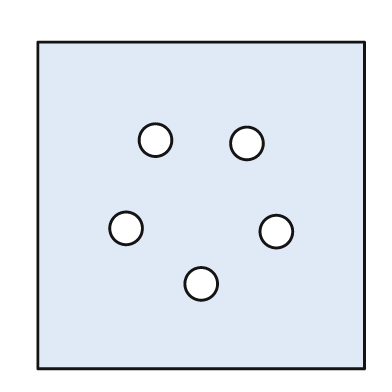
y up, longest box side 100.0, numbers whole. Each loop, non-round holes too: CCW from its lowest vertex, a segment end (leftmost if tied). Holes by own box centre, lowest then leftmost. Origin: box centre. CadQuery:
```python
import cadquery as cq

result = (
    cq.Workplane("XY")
    .moveTo(-50.0, -50.0)
    .lineTo(50.0, -50.0)
    .lineTo(50.0, 50.0)
    .lineTo(-50.0, 50.0)
    .close()
    .moveTo(0.0, -24.0)
    .circle(5.0)
    .moveTo(23.0, -8.0)
    .circle(5.0)
    .moveTo(-23.0, -7.0)
    .circle(5.0)
    .moveTo(14.0, 19.0)
    .circle(5.0)
    .moveTo(-14.0, 20.0)
    .circle(5.0)
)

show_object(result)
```